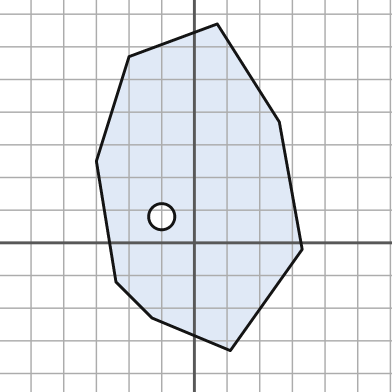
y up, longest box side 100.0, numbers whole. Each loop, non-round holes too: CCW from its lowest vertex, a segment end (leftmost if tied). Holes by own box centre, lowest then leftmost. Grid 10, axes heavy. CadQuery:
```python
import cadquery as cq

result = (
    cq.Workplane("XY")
    .moveTo(11.0, -33.0)
    .lineTo(33.0, -2.0)
    .lineTo(26.0, 37.0)
    .lineTo(7.0, 67.0)
    .lineTo(-20.0, 57.0)
    .lineTo(-30.0, 25.0)
    .lineTo(-24.0, -12.0)
    .lineTo(-13.0, -23.0)
    .close()
    .moveTo(-10.0, 8.0)
    .circle(4.0)
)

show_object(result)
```